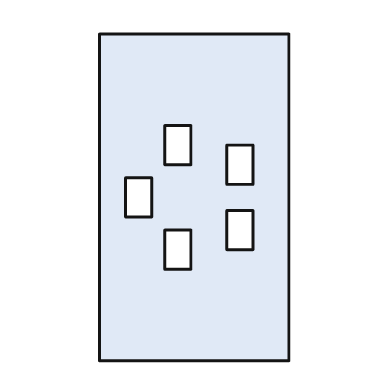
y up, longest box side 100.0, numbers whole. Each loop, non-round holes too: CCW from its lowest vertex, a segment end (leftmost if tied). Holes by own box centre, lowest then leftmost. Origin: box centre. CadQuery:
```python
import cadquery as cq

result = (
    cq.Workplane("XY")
    .moveTo(-29.0, -50.0)
    .lineTo(29.0, -50.0)
    .lineTo(29.0, 50.0)
    .lineTo(-29.0, 50.0)
    .close()
    .moveTo(-9.0, -22.0)
    .lineTo(-1.0, -22.0)
    .lineTo(-1.0, -10.0)
    .lineTo(-9.0, -10.0)
    .close()
    .moveTo(10.0, -16.0)
    .lineTo(18.0, -16.0)
    .lineTo(18.0, -4.0)
    .lineTo(10.0, -4.0)
    .close()
    .moveTo(-21.0, -6.0)
    .lineTo(-13.0, -6.0)
    .lineTo(-13.0, 6.0)
    .lineTo(-21.0, 6.0)
    .close()
    .moveTo(10.0, 4.0)
    .lineTo(18.0, 4.0)
    .lineTo(18.0, 16.0)
    .lineTo(10.0, 16.0)
    .close()
    .moveTo(-9.0, 10.0)
    .lineTo(-1.0, 10.0)
    .lineTo(-1.0, 22.0)
    .lineTo(-9.0, 22.0)
    .close()
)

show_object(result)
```